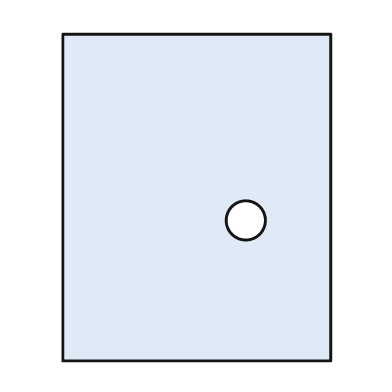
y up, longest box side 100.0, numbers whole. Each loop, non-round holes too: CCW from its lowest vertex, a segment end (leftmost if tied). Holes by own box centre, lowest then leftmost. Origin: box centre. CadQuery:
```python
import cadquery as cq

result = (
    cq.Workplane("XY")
    .moveTo(-41.0, -50.0)
    .lineTo(41.0, -50.0)
    .lineTo(41.0, 50.0)
    .lineTo(-41.0, 50.0)
    .close()
    .moveTo(15.0, -7.0)
    .circle(6.0)
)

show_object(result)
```